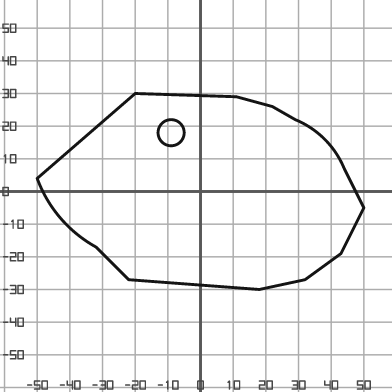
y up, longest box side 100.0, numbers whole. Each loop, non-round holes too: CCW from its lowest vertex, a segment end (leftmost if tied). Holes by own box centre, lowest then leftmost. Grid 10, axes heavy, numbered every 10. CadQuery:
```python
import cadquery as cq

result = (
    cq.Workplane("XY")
    .moveTo(18.0, -30.0)
    .lineTo(32.0, -27.0)
    .lineTo(43.0, -19.0)
    .lineTo(50.0, -5.0)
    .lineTo(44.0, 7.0)
    .threePointArc((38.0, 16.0), (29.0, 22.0))
    .lineTo(22.0, 26.0)
    .lineTo(11.0, 29.0)
    .lineTo(-20.0, 30.0)
    .lineTo(-50.0, 4.0)
    .threePointArc((-43.0, -8.0), (-32.0, -17.0))
    .lineTo(-22.0, -27.0)
    .close()
    .moveTo(-9.0, 18.0)
    .circle(4.0)
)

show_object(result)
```